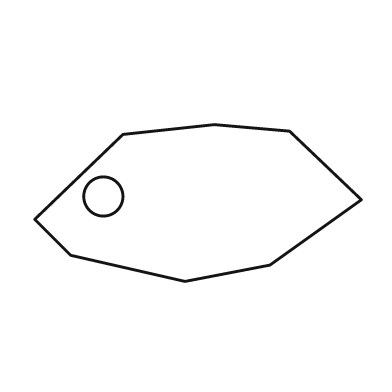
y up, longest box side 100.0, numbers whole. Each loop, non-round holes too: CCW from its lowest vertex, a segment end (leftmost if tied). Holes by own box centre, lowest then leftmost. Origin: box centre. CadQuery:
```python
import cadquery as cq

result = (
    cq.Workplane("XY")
    .moveTo(-4.0, -24.0)
    .lineTo(22.0, -19.0)
    .lineTo(50.0, 1.0)
    .lineTo(28.0, 22.0)
    .lineTo(5.0, 24.0)
    .lineTo(-23.0, 21.0)
    .lineTo(-50.0, -5.0)
    .lineTo(-39.0, -16.0)
    .close()
    .moveTo(-29.0, 2.0)
    .circle(6.0)
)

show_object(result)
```